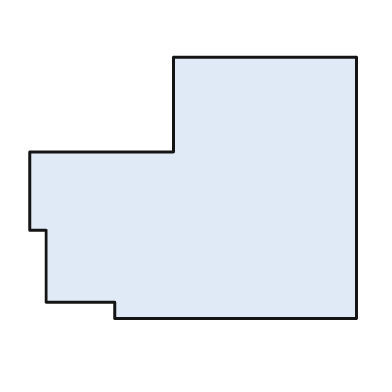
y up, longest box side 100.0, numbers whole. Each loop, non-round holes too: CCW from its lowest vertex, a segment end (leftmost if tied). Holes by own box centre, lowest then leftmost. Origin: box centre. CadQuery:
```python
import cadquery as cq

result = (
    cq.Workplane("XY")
    .moveTo(-24.0, -40.0)
    .lineTo(50.0, -40.0)
    .lineTo(50.0, 40.0)
    .lineTo(-6.0, 40.0)
    .lineTo(-6.0, 11.0)
    .lineTo(-50.0, 11.0)
    .lineTo(-50.0, -13.0)
    .lineTo(-45.0, -13.0)
    .lineTo(-45.0, -35.0)
    .lineTo(-24.0, -35.0)
    .close()
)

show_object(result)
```